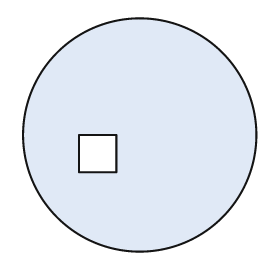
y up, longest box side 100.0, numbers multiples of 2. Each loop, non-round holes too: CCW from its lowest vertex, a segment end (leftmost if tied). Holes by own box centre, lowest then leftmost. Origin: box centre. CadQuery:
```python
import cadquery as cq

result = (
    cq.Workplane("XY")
    .moveTo(0.0, 0.0)
    .circle(50.0)
    .moveTo(-26.0, -16.0)
    .lineTo(-10.0, -16.0)
    .lineTo(-10.0, 0.0)
    .lineTo(-26.0, 0.0)
    .close()
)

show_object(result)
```